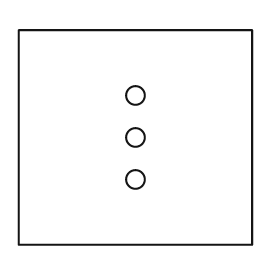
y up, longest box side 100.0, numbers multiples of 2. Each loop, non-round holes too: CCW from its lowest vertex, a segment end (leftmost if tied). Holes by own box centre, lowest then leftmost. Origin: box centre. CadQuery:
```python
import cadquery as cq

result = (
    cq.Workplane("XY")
    .moveTo(-50.0, -46.0)
    .lineTo(50.0, -46.0)
    .lineTo(50.0, 46.0)
    .lineTo(-50.0, 46.0)
    .close()
    .moveTo(0.0, -18.0)
    .circle(4.0)
    .moveTo(0.0, 0.0)
    .circle(4.0)
    .moveTo(0.0, 18.0)
    .circle(4.0)
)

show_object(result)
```